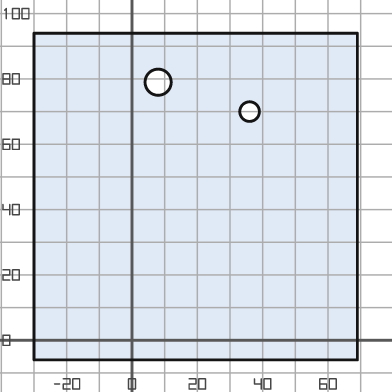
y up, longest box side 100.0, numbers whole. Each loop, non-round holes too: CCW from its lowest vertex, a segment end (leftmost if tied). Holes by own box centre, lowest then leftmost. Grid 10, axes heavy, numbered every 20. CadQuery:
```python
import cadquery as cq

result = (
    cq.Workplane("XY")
    .moveTo(-30.0, -6.0)
    .lineTo(69.0, -6.0)
    .lineTo(69.0, 94.0)
    .lineTo(-30.0, 94.0)
    .close()
    .moveTo(36.0, 70.0)
    .circle(3.0)
    .moveTo(8.0, 79.0)
    .circle(4.0)
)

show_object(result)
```